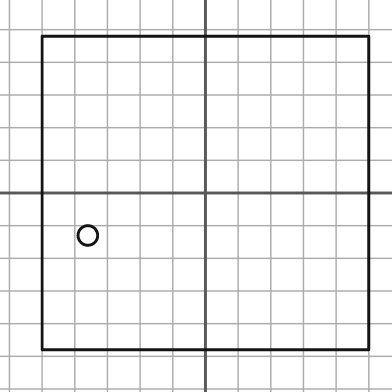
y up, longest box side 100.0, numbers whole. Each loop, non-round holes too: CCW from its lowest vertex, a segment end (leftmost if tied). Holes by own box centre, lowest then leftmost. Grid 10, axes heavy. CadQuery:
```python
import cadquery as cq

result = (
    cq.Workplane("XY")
    .moveTo(-50.0, -48.0)
    .lineTo(50.0, -48.0)
    .lineTo(50.0, 48.0)
    .lineTo(-50.0, 48.0)
    .close()
    .moveTo(-36.0, -13.0)
    .circle(3.0)
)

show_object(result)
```